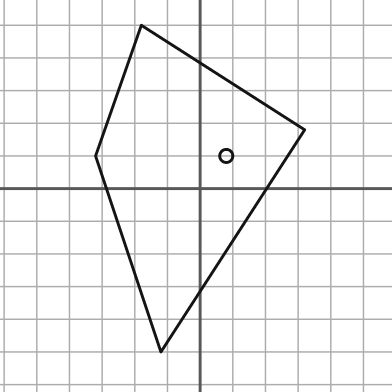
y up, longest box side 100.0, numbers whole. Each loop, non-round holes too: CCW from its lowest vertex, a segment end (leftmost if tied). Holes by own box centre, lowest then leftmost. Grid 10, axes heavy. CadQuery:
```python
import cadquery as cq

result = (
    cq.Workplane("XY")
    .moveTo(-12.0, -50.0)
    .lineTo(32.0, 18.0)
    .lineTo(-18.0, 50.0)
    .lineTo(-32.0, 10.0)
    .close()
    .moveTo(8.0, 10.0)
    .circle(2.0)
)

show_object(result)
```